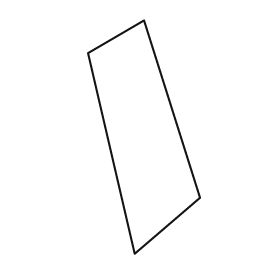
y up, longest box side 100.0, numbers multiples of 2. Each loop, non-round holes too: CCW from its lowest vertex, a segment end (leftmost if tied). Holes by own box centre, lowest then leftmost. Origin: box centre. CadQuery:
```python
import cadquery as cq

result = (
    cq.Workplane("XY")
    .moveTo(-4.0, -50.0)
    .lineTo(24.0, -26.0)
    .lineTo(0.0, 50.0)
    .lineTo(-24.0, 36.0)
    .close()
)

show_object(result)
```